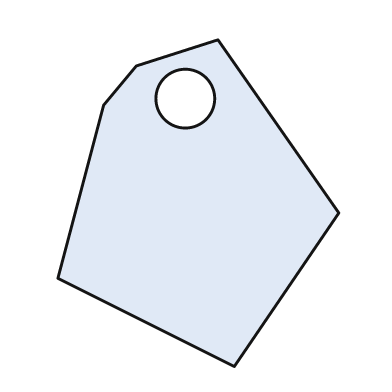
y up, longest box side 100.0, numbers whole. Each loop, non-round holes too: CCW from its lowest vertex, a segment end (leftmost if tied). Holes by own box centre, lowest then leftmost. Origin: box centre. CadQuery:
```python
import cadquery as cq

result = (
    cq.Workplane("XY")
    .moveTo(11.0, -50.0)
    .lineTo(43.0, -3.0)
    .lineTo(6.0, 50.0)
    .lineTo(-19.0, 42.0)
    .lineTo(-29.0, 30.0)
    .lineTo(-43.0, -23.0)
    .close()
    .moveTo(-4.0, 32.0)
    .circle(9.0)
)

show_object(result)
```